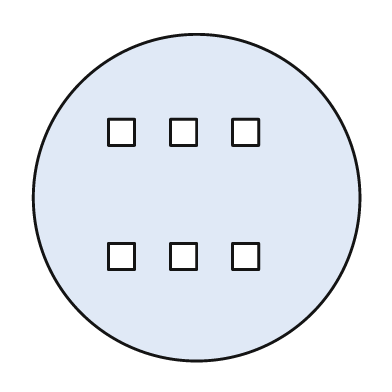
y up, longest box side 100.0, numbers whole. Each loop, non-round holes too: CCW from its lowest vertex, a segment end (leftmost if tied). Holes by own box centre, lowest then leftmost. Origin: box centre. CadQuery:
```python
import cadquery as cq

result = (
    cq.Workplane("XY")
    .moveTo(0.0, 0.0)
    .circle(50.0)
    .moveTo(-27.0, -22.0)
    .lineTo(-19.0, -22.0)
    .lineTo(-19.0, -14.0)
    .lineTo(-27.0, -14.0)
    .close()
    .moveTo(-8.0, -22.0)
    .lineTo(0.0, -22.0)
    .lineTo(0.0, -14.0)
    .lineTo(-8.0, -14.0)
    .close()
    .moveTo(11.0, -22.0)
    .lineTo(19.0, -22.0)
    .lineTo(19.0, -14.0)
    .lineTo(11.0, -14.0)
    .close()
    .moveTo(-27.0, 16.0)
    .lineTo(-19.0, 16.0)
    .lineTo(-19.0, 24.0)
    .lineTo(-27.0, 24.0)
    .close()
    .moveTo(-8.0, 16.0)
    .lineTo(0.0, 16.0)
    .lineTo(0.0, 24.0)
    .lineTo(-8.0, 24.0)
    .close()
    .moveTo(11.0, 16.0)
    .lineTo(19.0, 16.0)
    .lineTo(19.0, 24.0)
    .lineTo(11.0, 24.0)
    .close()
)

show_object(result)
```